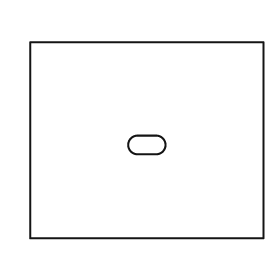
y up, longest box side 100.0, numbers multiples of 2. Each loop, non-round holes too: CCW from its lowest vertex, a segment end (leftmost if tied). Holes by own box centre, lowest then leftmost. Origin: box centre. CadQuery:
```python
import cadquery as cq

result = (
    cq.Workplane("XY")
    .moveTo(-50.0, -42.0)
    .lineTo(50.0, -42.0)
    .lineTo(50.0, 42.0)
    .lineTo(-50.0, 42.0)
    .close()
    .moveTo(-4.0, -6.0)
    .lineTo(4.0, -6.0)
    .threePointArc((8.0, -2.0), (4.0, 2.0))
    .lineTo(-4.0, 2.0)
    .threePointArc((-8.0, -2.0), (-4.0, -6.0))
    .close()
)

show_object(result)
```